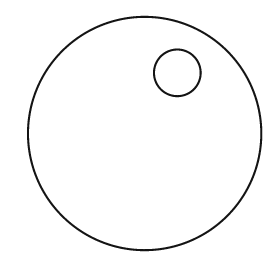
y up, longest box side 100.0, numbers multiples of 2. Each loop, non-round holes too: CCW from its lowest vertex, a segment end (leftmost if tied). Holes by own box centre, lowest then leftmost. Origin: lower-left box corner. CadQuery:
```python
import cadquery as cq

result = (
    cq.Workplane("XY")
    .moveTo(50.0, 50.0)
    .circle(50.0)
    .moveTo(64.0, 76.0)
    .circle(10.0)
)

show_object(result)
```